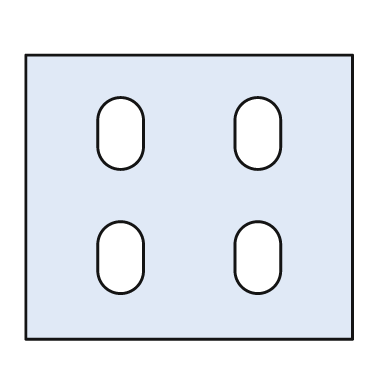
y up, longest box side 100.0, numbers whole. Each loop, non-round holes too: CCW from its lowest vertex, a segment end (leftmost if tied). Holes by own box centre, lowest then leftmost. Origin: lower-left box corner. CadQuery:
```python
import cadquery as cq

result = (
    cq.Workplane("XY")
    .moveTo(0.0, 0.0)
    .lineTo(100.0, 0.0)
    .lineTo(100.0, 87.0)
    .lineTo(0.0, 87.0)
    .close()
    .moveTo(22.0, 21.0)
    .threePointArc((29.0, 14.0), (36.0, 21.0))
    .lineTo(36.0, 29.0)
    .threePointArc((29.0, 36.0), (22.0, 29.0))
    .close()
    .moveTo(64.0, 21.0)
    .threePointArc((71.0, 14.0), (78.0, 21.0))
    .lineTo(78.0, 29.0)
    .threePointArc((71.0, 36.0), (64.0, 29.0))
    .close()
    .moveTo(22.0, 59.0)
    .threePointArc((29.0, 52.0), (36.0, 59.0))
    .lineTo(36.0, 67.0)
    .threePointArc((29.0, 74.0), (22.0, 67.0))
    .close()
    .moveTo(64.0, 59.0)
    .threePointArc((71.0, 52.0), (78.0, 59.0))
    .lineTo(78.0, 67.0)
    .threePointArc((71.0, 74.0), (64.0, 67.0))
    .close()
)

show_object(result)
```